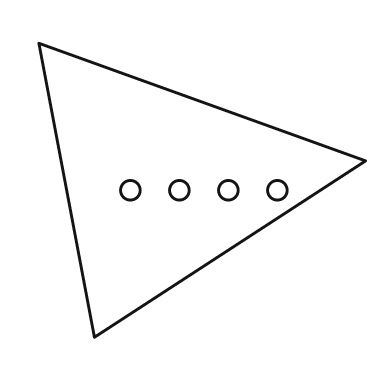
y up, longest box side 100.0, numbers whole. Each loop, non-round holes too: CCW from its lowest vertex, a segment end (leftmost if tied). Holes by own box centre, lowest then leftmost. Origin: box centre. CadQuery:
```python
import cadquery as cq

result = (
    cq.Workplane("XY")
    .moveTo(-33.0, -45.0)
    .lineTo(50.0, 9.0)
    .lineTo(-50.0, 45.0)
    .close()
    .moveTo(-22.0, 0.0)
    .circle(3.0)
    .moveTo(-7.0, 0.0)
    .circle(3.0)
    .moveTo(8.0, 0.0)
    .circle(3.0)
    .moveTo(23.0, 0.0)
    .circle(3.0)
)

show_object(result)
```